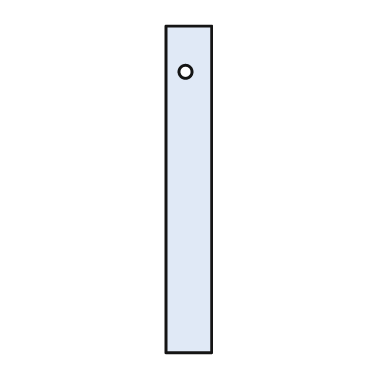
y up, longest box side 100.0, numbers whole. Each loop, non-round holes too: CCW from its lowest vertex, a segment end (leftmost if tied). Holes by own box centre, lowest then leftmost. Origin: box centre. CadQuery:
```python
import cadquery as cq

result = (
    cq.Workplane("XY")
    .moveTo(-7.0, -50.0)
    .lineTo(7.0, -50.0)
    .lineTo(7.0, 50.0)
    .lineTo(-7.0, 50.0)
    .close()
    .moveTo(-1.0, 36.0)
    .circle(2.0)
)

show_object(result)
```